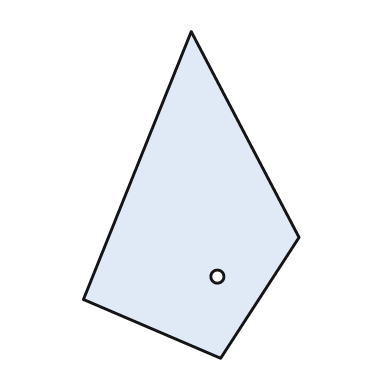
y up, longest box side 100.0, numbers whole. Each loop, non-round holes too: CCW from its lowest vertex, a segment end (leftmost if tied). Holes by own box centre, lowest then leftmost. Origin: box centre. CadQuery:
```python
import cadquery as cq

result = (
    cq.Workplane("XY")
    .moveTo(9.0, -50.0)
    .lineTo(33.0, -13.0)
    .lineTo(0.0, 50.0)
    .lineTo(-33.0, -32.0)
    .close()
    .moveTo(8.0, -25.0)
    .circle(2.0)
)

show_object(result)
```